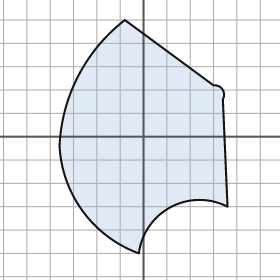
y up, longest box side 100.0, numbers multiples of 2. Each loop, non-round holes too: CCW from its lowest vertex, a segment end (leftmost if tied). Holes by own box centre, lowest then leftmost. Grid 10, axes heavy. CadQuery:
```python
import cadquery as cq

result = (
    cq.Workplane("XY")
    .moveTo(-2.0, -50.0)
    .threePointArc((12.0, -30.0), (36.0, -30.0))
    .lineTo(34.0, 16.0)
    .threePointArc((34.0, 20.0), (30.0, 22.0))
    .lineTo(-8.0, 50.0)
    .threePointArc((-28.0, 26.0), (-36.0, -4.0))
    .threePointArc((-26.0, -32.0), (-2.0, -50.0))
    .close()
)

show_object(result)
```